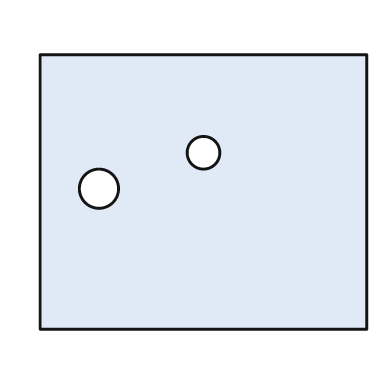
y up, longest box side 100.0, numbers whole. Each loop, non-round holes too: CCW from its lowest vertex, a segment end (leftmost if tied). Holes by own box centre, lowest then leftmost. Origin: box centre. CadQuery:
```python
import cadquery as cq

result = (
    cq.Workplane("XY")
    .moveTo(-50.0, -42.0)
    .lineTo(50.0, -42.0)
    .lineTo(50.0, 42.0)
    .lineTo(-50.0, 42.0)
    .close()
    .moveTo(-32.0, 1.0)
    .circle(6.0)
    .moveTo(0.0, 12.0)
    .circle(5.0)
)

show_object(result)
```